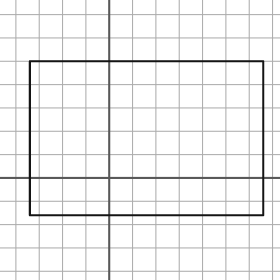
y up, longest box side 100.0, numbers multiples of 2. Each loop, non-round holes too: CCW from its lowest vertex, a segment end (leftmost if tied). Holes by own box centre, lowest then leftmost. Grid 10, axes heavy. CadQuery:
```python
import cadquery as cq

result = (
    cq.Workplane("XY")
    .moveTo(-34.0, -16.0)
    .lineTo(66.0, -16.0)
    .lineTo(66.0, 50.0)
    .lineTo(-34.0, 50.0)
    .close()
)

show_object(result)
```